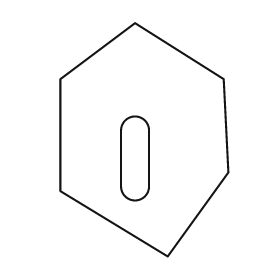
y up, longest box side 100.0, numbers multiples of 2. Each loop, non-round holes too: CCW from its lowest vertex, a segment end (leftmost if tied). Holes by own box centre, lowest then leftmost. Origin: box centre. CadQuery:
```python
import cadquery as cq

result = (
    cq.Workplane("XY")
    .moveTo(10.0, -50.0)
    .lineTo(36.0, -14.0)
    .lineTo(34.0, 26.0)
    .lineTo(-4.0, 50.0)
    .lineTo(-36.0, 26.0)
    .lineTo(-36.0, -22.0)
    .close()
    .moveTo(-10.0, -20.0)
    .threePointArc((-4.0, -26.0), (2.0, -20.0))
    .lineTo(2.0, 4.0)
    .threePointArc((-4.0, 10.0), (-10.0, 4.0))
    .close()
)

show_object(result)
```